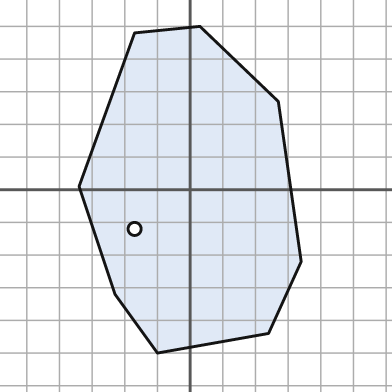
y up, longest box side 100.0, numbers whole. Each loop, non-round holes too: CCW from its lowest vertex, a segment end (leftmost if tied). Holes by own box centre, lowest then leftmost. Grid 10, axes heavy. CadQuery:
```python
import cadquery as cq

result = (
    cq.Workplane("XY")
    .moveTo(-10.0, -50.0)
    .lineTo(24.0, -44.0)
    .lineTo(34.0, -22.0)
    .lineTo(27.0, 27.0)
    .lineTo(3.0, 50.0)
    .lineTo(-17.0, 48.0)
    .lineTo(-34.0, 1.0)
    .lineTo(-23.0, -32.0)
    .close()
    .moveTo(-17.0, -12.0)
    .circle(2.0)
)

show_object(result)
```